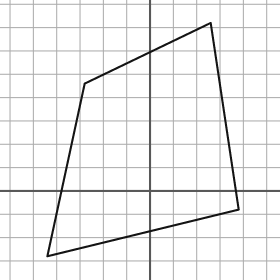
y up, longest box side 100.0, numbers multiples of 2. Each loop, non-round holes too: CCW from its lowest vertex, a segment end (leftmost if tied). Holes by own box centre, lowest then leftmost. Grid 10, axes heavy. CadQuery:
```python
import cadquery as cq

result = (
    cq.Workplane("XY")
    .moveTo(-44.0, -28.0)
    .lineTo(38.0, -8.0)
    .lineTo(26.0, 72.0)
    .lineTo(-28.0, 46.0)
    .close()
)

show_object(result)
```